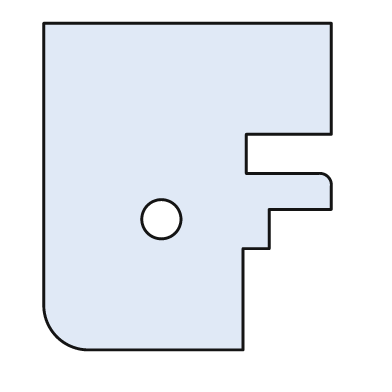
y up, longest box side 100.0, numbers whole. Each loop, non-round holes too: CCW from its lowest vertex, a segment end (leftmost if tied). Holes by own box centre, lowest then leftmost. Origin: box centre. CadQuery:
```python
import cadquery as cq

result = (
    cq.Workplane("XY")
    .moveTo(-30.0, -50.0)
    .lineTo(17.0, -50.0)
    .lineTo(17.0, -19.0)
    .lineTo(25.0, -19.0)
    .lineTo(25.0, -7.0)
    .lineTo(44.0, -7.0)
    .lineTo(44.0, 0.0)
    .threePointArc((43.0, 3.0), (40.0, 4.0))
    .lineTo(18.0, 4.0)
    .lineTo(18.0, 16.0)
    .lineTo(44.0, 16.0)
    .lineTo(44.0, 50.0)
    .lineTo(-44.0, 50.0)
    .lineTo(-44.0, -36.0)
    .threePointArc((-40.0, -46.0), (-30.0, -50.0))
    .close()
    .moveTo(-8.0, -10.0)
    .circle(6.0)
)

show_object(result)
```